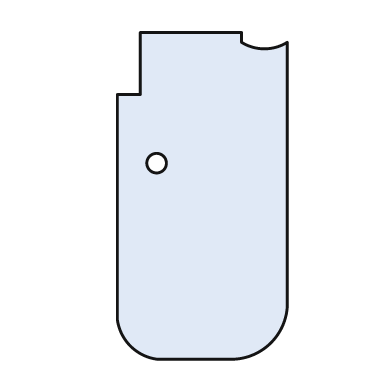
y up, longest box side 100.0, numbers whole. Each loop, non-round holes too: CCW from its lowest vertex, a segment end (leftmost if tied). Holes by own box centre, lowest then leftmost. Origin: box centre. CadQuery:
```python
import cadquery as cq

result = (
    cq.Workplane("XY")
    .moveTo(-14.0, -50.0)
    .lineTo(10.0, -50.0)
    .threePointArc((21.0, -45.0), (26.0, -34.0))
    .lineTo(26.0, 47.0)
    .threePointArc((19.0, 45.0), (12.0, 47.0))
    .lineTo(12.0, 50.0)
    .lineTo(-19.0, 50.0)
    .lineTo(-19.0, 31.0)
    .lineTo(-26.0, 31.0)
    .lineTo(-26.0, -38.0)
    .threePointArc((-22.0, -46.0), (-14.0, -50.0))
    .close()
    .moveTo(-14.0, 10.0)
    .circle(3.0)
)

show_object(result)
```